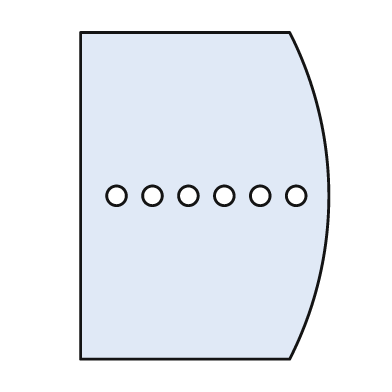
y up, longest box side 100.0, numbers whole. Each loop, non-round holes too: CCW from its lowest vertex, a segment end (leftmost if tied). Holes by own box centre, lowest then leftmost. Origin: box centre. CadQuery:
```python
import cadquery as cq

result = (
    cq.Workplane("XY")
    .moveTo(-38.0, -50.0)
    .lineTo(26.0, -50.0)
    .threePointArc((38.0, 0.0), (26.0, 50.0))
    .lineTo(-38.0, 50.0)
    .close()
    .moveTo(-27.0, 0.0)
    .circle(3.0)
    .moveTo(-16.0, 0.0)
    .circle(3.0)
    .moveTo(-5.0, 0.0)
    .circle(3.0)
    .moveTo(6.0, 0.0)
    .circle(3.0)
    .moveTo(17.0, 0.0)
    .circle(3.0)
    .moveTo(28.0, 0.0)
    .circle(3.0)
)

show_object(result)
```